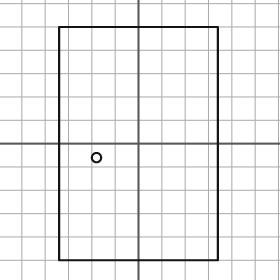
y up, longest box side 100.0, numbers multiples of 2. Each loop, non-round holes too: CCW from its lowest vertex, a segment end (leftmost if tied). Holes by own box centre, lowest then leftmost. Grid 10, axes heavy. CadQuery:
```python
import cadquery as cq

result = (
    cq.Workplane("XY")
    .moveTo(-34.0, -50.0)
    .lineTo(34.0, -50.0)
    .lineTo(34.0, 50.0)
    .lineTo(-34.0, 50.0)
    .close()
    .moveTo(-18.0, -6.0)
    .circle(2.0)
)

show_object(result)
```